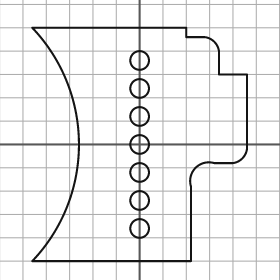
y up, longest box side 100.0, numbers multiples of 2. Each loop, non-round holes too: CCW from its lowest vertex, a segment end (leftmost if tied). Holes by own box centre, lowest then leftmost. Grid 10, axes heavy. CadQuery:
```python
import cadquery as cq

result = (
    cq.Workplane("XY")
    .moveTo(-46.0, -50.0)
    .lineTo(22.0, -50.0)
    .lineTo(22.0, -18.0)
    .threePointArc((24.0, -10.0), (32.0, -8.0))
    .lineTo(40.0, -8.0)
    .threePointArc((44.0, -6.0), (46.0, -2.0))
    .lineTo(46.0, 30.0)
    .lineTo(34.0, 30.0)
    .lineTo(34.0, 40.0)
    .threePointArc((32.0, 44.0), (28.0, 46.0))
    .lineTo(20.0, 46.0)
    .lineTo(20.0, 50.0)
    .lineTo(-46.0, 50.0)
    .threePointArc((-26.0, 0.0), (-46.0, -50.0))
    .close()
    .moveTo(0.0, -36.0)
    .circle(4.0)
    .moveTo(0.0, -24.0)
    .circle(4.0)
    .moveTo(0.0, -12.0)
    .circle(4.0)
    .moveTo(0.0, 0.0)
    .circle(4.0)
    .moveTo(0.0, 12.0)
    .circle(4.0)
    .moveTo(0.0, 24.0)
    .circle(4.0)
    .moveTo(0.0, 36.0)
    .circle(4.0)
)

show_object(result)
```